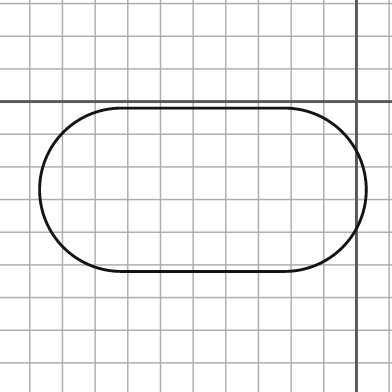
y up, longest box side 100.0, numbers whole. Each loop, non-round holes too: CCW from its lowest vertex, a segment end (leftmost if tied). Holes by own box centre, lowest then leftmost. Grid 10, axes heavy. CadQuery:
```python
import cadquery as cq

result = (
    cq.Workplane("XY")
    .moveTo(-72.0, -52.0)
    .lineTo(-22.0, -52.0)
    .threePointArc((3.0, -27.0), (-22.0, -2.0))
    .lineTo(-72.0, -2.0)
    .threePointArc((-97.0, -27.0), (-72.0, -52.0))
    .close()
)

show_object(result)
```